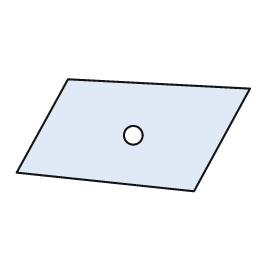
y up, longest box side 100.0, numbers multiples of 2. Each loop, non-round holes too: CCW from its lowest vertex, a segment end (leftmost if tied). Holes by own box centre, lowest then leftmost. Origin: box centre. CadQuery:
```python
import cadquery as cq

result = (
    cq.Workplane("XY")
    .moveTo(26.0, -24.0)
    .lineTo(50.0, 20.0)
    .lineTo(-28.0, 24.0)
    .lineTo(-50.0, -16.0)
    .close()
    .moveTo(0.0, 0.0)
    .circle(4.0)
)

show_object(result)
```